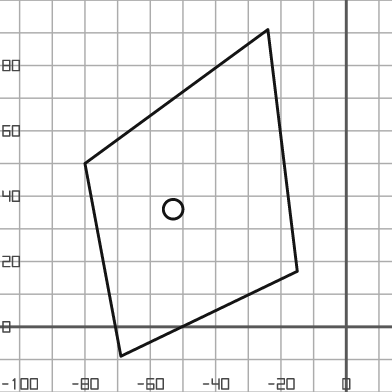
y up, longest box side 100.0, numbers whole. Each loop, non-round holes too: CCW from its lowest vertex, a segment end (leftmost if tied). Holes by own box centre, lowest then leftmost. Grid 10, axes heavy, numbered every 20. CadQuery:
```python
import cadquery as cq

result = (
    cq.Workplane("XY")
    .moveTo(-69.0, -9.0)
    .lineTo(-15.0, 17.0)
    .lineTo(-24.0, 91.0)
    .lineTo(-80.0, 50.0)
    .close()
    .moveTo(-53.0, 36.0)
    .circle(3.0)
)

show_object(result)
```